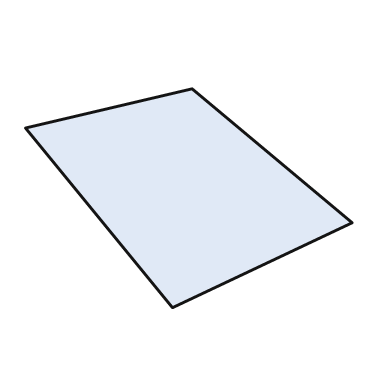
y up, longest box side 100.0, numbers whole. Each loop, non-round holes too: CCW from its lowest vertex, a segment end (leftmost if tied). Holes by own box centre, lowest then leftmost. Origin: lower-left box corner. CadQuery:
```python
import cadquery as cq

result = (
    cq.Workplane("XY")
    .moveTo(45.0, 0.0)
    .lineTo(100.0, 26.0)
    .lineTo(51.0, 67.0)
    .lineTo(0.0, 55.0)
    .close()
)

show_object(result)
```